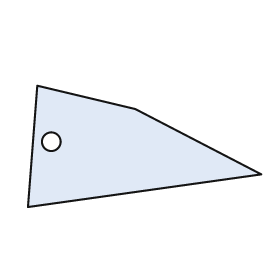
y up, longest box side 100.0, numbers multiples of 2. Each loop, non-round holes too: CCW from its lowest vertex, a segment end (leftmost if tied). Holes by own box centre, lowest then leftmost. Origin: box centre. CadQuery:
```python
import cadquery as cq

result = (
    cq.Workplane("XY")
    .moveTo(-50.0, -26.0)
    .lineTo(50.0, -12.0)
    .lineTo(-4.0, 16.0)
    .lineTo(-46.0, 26.0)
    .close()
    .moveTo(-40.0, 2.0)
    .circle(4.0)
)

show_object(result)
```